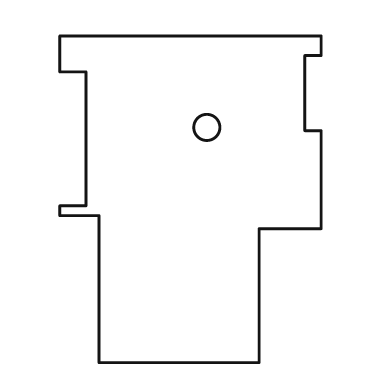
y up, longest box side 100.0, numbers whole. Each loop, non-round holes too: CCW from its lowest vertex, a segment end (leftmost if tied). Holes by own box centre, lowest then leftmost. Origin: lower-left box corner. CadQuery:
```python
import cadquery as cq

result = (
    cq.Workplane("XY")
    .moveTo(12.0, 0.0)
    .lineTo(61.0, 0.0)
    .lineTo(61.0, 41.0)
    .lineTo(80.0, 41.0)
    .lineTo(80.0, 71.0)
    .lineTo(75.0, 71.0)
    .lineTo(75.0, 94.0)
    .lineTo(80.0, 94.0)
    .lineTo(80.0, 100.0)
    .lineTo(0.0, 100.0)
    .lineTo(0.0, 89.0)
    .lineTo(8.0, 89.0)
    .lineTo(8.0, 48.0)
    .lineTo(0.0, 48.0)
    .lineTo(0.0, 45.0)
    .lineTo(12.0, 45.0)
    .close()
    .moveTo(45.0, 72.0)
    .circle(4.0)
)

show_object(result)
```